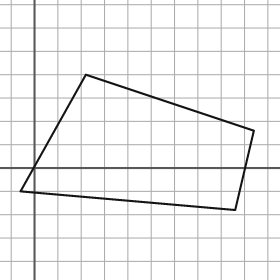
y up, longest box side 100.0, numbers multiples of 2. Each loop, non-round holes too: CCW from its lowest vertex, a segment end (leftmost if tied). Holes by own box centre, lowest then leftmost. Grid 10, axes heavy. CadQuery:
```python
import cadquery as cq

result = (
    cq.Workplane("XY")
    .moveTo(86.0, -18.0)
    .lineTo(94.0, 16.0)
    .lineTo(22.0, 40.0)
    .lineTo(-6.0, -10.0)
    .close()
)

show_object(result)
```